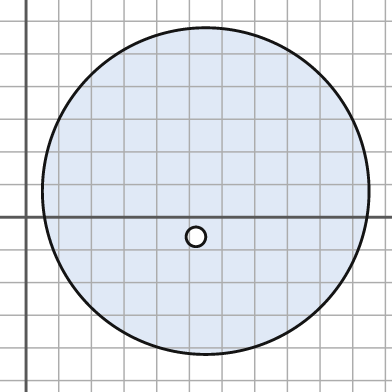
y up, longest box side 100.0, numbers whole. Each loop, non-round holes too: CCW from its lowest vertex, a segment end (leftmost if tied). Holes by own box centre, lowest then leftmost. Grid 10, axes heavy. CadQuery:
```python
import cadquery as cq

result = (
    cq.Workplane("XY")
    .moveTo(55.0, 8.0)
    .circle(50.0)
    .moveTo(52.0, -6.0)
    .circle(3.0)
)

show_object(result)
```